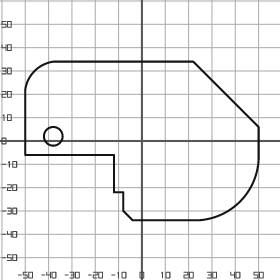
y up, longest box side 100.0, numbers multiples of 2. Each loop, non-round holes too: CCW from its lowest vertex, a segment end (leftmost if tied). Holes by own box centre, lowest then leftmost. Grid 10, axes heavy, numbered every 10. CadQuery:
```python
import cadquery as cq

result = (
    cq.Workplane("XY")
    .moveTo(-4.0, -34.0)
    .lineTo(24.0, -34.0)
    .threePointArc((42.0, -26.0), (50.0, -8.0))
    .lineTo(50.0, 6.0)
    .lineTo(22.0, 34.0)
    .lineTo(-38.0, 34.0)
    .threePointArc((-46.0, 30.0), (-50.0, 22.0))
    .lineTo(-50.0, -6.0)
    .lineTo(-12.0, -6.0)
    .lineTo(-12.0, -22.0)
    .lineTo(-8.0, -22.0)
    .lineTo(-8.0, -30.0)
    .close()
    .moveTo(-38.0, 2.0)
    .circle(4.0)
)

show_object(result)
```